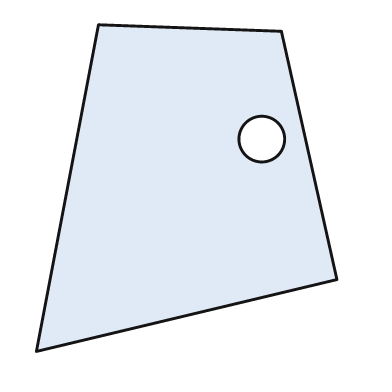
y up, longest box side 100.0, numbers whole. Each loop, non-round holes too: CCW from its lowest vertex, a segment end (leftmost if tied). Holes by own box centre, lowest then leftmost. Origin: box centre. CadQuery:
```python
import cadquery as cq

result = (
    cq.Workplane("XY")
    .moveTo(-46.0, -50.0)
    .lineTo(46.0, -28.0)
    .lineTo(29.0, 48.0)
    .lineTo(-27.0, 50.0)
    .close()
    .moveTo(23.0, 15.0)
    .circle(7.0)
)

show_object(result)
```